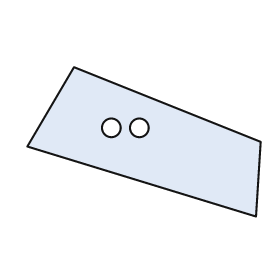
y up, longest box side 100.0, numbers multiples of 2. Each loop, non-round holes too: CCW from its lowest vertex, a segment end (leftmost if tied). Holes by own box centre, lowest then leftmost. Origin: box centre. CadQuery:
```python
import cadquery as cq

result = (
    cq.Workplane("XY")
    .moveTo(48.0, -32.0)
    .lineTo(50.0, 0.0)
    .lineTo(-30.0, 32.0)
    .lineTo(-50.0, -2.0)
    .close()
    .moveTo(-14.0, 6.0)
    .circle(4.0)
    .moveTo(-2.0, 6.0)
    .circle(4.0)
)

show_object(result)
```